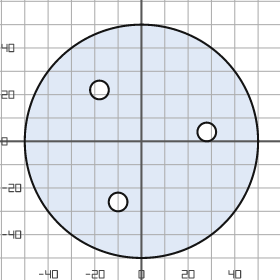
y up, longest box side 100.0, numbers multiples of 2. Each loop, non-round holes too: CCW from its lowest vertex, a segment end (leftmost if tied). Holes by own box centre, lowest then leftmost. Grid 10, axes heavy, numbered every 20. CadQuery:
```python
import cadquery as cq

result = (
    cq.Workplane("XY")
    .moveTo(0.0, 0.0)
    .circle(50.0)
    .moveTo(-10.0, -26.0)
    .circle(4.0)
    .moveTo(28.0, 4.0)
    .circle(4.0)
    .moveTo(-18.0, 22.0)
    .circle(4.0)
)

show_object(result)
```